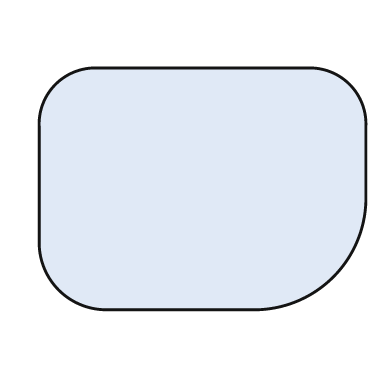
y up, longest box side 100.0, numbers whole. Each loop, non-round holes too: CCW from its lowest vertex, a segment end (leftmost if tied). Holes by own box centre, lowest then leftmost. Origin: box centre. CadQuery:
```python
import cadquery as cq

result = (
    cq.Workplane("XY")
    .moveTo(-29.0, -37.0)
    .lineTo(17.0, -37.0)
    .threePointArc((40.0, -27.0), (50.0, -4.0))
    .lineTo(50.0, 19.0)
    .threePointArc((45.0, 32.0), (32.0, 37.0))
    .lineTo(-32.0, 37.0)
    .threePointArc((-45.0, 32.0), (-50.0, 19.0))
    .lineTo(-50.0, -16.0)
    .threePointArc((-44.0, -31.0), (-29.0, -37.0))
    .close()
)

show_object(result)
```